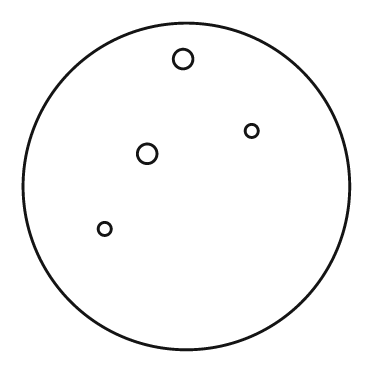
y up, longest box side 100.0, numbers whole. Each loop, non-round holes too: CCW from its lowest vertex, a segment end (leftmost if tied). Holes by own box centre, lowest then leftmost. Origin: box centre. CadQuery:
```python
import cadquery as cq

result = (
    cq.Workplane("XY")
    .moveTo(0.0, 0.0)
    .circle(50.0)
    .moveTo(-25.0, -13.0)
    .circle(2.0)
    .moveTo(-12.0, 10.0)
    .circle(3.0)
    .moveTo(20.0, 17.0)
    .circle(2.0)
    .moveTo(-1.0, 39.0)
    .circle(3.0)
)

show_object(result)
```